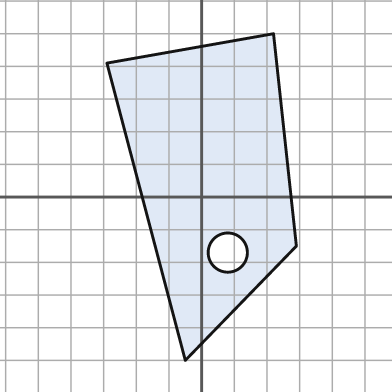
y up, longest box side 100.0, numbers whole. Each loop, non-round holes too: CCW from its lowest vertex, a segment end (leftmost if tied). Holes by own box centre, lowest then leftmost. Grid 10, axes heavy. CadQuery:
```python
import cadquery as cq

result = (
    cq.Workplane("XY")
    .moveTo(-5.0, -50.0)
    .lineTo(29.0, -15.0)
    .lineTo(22.0, 50.0)
    .lineTo(-29.0, 41.0)
    .close()
    .moveTo(8.0, -17.0)
    .circle(6.0)
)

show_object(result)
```